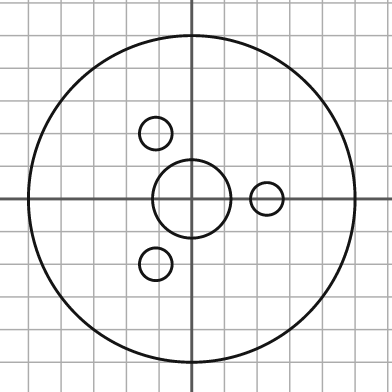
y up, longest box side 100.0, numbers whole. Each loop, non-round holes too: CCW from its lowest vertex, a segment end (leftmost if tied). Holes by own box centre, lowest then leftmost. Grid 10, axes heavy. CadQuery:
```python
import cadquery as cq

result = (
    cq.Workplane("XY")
    .moveTo(0.0, 0.0)
    .circle(50.0)
    .moveTo(-11.0, -20.0)
    .circle(5.0)
    .moveTo(0.0, 0.0)
    .circle(12.0)
    .moveTo(23.0, 0.0)
    .circle(5.0)
    .moveTo(-11.0, 20.0)
    .circle(5.0)
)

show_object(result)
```